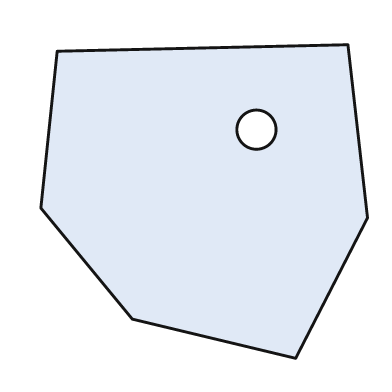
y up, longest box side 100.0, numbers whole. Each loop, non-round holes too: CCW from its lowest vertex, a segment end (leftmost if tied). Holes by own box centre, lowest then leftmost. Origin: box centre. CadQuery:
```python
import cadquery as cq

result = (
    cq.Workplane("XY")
    .moveTo(28.0, -48.0)
    .lineTo(50.0, -5.0)
    .lineTo(44.0, 48.0)
    .lineTo(-45.0, 46.0)
    .lineTo(-50.0, -2.0)
    .lineTo(-22.0, -36.0)
    .close()
    .moveTo(16.0, 22.0)
    .circle(6.0)
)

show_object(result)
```